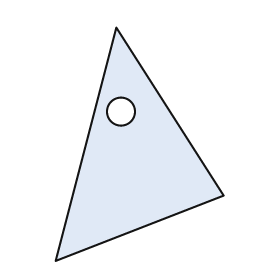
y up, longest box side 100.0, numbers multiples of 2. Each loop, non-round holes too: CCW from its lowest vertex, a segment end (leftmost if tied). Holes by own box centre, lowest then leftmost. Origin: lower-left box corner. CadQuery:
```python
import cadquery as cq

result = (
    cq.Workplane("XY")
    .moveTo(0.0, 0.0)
    .lineTo(72.0, 28.0)
    .lineTo(26.0, 100.0)
    .close()
    .moveTo(28.0, 64.0)
    .circle(6.0)
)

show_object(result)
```